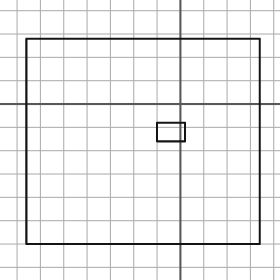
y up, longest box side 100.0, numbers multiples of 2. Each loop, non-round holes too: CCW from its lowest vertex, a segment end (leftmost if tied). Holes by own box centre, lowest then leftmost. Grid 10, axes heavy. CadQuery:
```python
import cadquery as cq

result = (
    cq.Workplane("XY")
    .moveTo(-66.0, -60.0)
    .lineTo(34.0, -60.0)
    .lineTo(34.0, 28.0)
    .lineTo(-66.0, 28.0)
    .close()
    .moveTo(-10.0, -16.0)
    .lineTo(2.0, -16.0)
    .lineTo(2.0, -8.0)
    .lineTo(-10.0, -8.0)
    .close()
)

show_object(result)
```